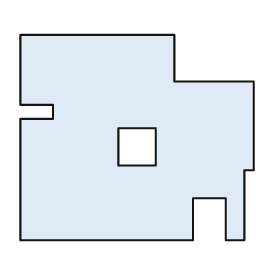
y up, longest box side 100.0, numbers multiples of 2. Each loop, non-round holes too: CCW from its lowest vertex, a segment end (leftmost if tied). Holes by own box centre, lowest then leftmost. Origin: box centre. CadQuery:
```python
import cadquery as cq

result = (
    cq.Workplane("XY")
    .moveTo(-50.0, -44.0)
    .lineTo(24.0, -44.0)
    .lineTo(24.0, -26.0)
    .lineTo(38.0, -26.0)
    .lineTo(38.0, -44.0)
    .lineTo(46.0, -44.0)
    .lineTo(46.0, -14.0)
    .lineTo(50.0, -14.0)
    .lineTo(50.0, 24.0)
    .lineTo(16.0, 24.0)
    .lineTo(16.0, 44.0)
    .lineTo(-50.0, 44.0)
    .lineTo(-50.0, 14.0)
    .lineTo(-36.0, 14.0)
    .lineTo(-36.0, 8.0)
    .lineTo(-50.0, 8.0)
    .close()
    .moveTo(-8.0, -12.0)
    .lineTo(8.0, -12.0)
    .lineTo(8.0, 4.0)
    .lineTo(-8.0, 4.0)
    .close()
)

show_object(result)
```